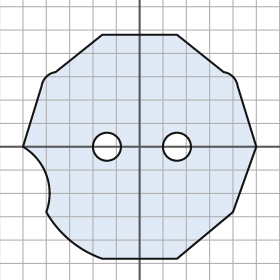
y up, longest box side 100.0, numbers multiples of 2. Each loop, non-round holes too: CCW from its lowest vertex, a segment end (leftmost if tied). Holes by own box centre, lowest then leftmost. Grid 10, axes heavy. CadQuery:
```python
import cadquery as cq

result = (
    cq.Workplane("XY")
    .moveTo(-16.0, -48.0)
    .lineTo(16.0, -48.0)
    .lineTo(40.0, -28.0)
    .lineTo(50.0, 0.0)
    .lineTo(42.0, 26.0)
    .threePointArc((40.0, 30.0), (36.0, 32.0))
    .lineTo(16.0, 48.0)
    .lineTo(-16.0, 48.0)
    .lineTo(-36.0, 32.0)
    .threePointArc((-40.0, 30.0), (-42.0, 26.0))
    .lineTo(-50.0, 0.0)
    .threePointArc((-40.0, -12.0), (-40.0, -28.0))
    .threePointArc((-30.0, -40.0), (-16.0, -48.0))
    .close()
    .moveTo(-14.0, 0.0)
    .circle(6.0)
    .moveTo(16.0, 0.0)
    .circle(6.0)
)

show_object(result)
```